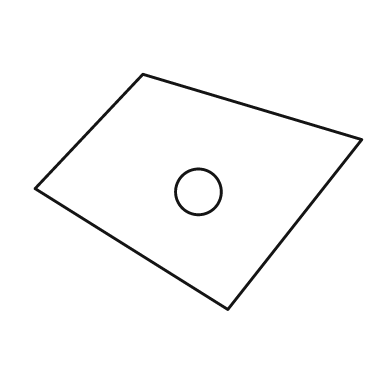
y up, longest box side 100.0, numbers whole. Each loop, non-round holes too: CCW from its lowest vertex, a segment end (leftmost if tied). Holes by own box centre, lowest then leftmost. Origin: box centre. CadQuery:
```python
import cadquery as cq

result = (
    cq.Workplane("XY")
    .moveTo(9.0, -36.0)
    .lineTo(50.0, 16.0)
    .lineTo(-17.0, 36.0)
    .lineTo(-50.0, 1.0)
    .close()
    .moveTo(0.0, 0.0)
    .circle(7.0)
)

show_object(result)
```